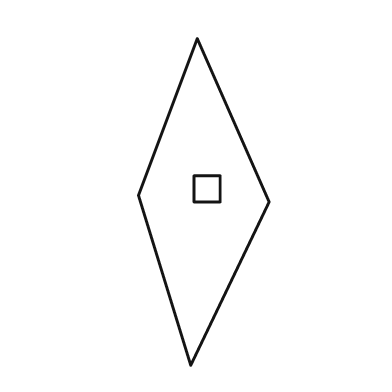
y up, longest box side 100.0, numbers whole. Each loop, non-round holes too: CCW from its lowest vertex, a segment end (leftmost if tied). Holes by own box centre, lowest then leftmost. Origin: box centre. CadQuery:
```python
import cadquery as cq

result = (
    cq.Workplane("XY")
    .moveTo(-4.0, -50.0)
    .lineTo(20.0, 0.0)
    .lineTo(-2.0, 50.0)
    .lineTo(-20.0, 2.0)
    .close()
    .moveTo(-3.0, 0.0)
    .lineTo(5.0, 0.0)
    .lineTo(5.0, 8.0)
    .lineTo(-3.0, 8.0)
    .close()
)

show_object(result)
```